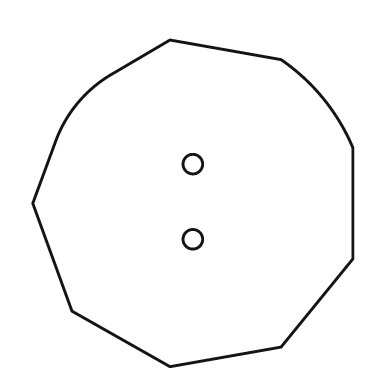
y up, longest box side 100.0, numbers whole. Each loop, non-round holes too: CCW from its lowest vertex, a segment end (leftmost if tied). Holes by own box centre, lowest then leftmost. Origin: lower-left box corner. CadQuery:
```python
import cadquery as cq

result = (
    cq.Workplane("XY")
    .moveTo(42.0, 0.0)
    .lineTo(76.0, 6.0)
    .lineTo(98.0, 33.0)
    .lineTo(98.0, 67.0)
    .threePointArc((89.0, 82.0), (76.0, 94.0))
    .lineTo(42.0, 100.0)
    .lineTo(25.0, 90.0)
    .threePointArc((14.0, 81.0), (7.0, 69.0))
    .lineTo(0.0, 50.0)
    .lineTo(12.0, 17.0)
    .close()
    .moveTo(49.0, 39.0)
    .circle(3.0)
    .moveTo(49.0, 62.0)
    .circle(3.0)
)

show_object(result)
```